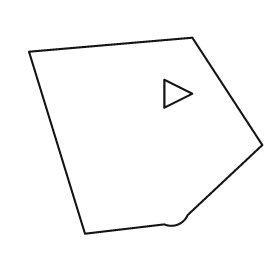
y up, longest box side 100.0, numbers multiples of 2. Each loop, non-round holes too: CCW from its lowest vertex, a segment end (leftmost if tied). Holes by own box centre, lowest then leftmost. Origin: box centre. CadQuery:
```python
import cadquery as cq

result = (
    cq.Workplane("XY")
    .moveTo(-26.0, -42.0)
    .lineTo(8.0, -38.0)
    .threePointArc((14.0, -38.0), (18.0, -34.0))
    .lineTo(50.0, -4.0)
    .lineTo(20.0, 42.0)
    .lineTo(-50.0, 36.0)
    .close()
    .moveTo(8.0, 12.0)
    .lineTo(20.0, 18.0)
    .lineTo(8.0, 24.0)
    .close()
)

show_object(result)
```